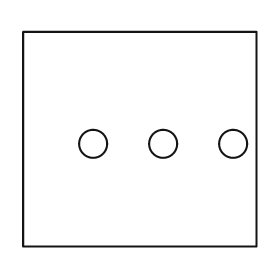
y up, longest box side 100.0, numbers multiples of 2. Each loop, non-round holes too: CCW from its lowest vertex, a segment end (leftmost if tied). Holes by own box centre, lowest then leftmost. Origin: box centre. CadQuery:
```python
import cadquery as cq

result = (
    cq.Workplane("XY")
    .moveTo(-50.0, -46.0)
    .lineTo(50.0, -46.0)
    .lineTo(50.0, 46.0)
    .lineTo(-50.0, 46.0)
    .close()
    .moveTo(-20.0, -2.0)
    .circle(6.0)
    .moveTo(10.0, -2.0)
    .circle(6.0)
    .moveTo(40.0, -2.0)
    .circle(6.0)
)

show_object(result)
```